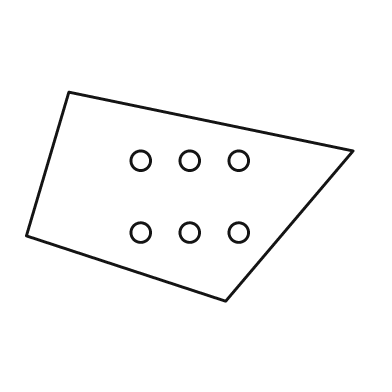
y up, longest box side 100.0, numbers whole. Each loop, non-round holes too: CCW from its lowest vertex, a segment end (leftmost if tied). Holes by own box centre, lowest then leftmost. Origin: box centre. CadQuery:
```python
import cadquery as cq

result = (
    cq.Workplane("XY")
    .moveTo(11.0, -32.0)
    .lineTo(50.0, 14.0)
    .lineTo(-37.0, 32.0)
    .lineTo(-50.0, -12.0)
    .close()
    .moveTo(-15.0, -11.0)
    .circle(3.0)
    .moveTo(0.0, -11.0)
    .circle(3.0)
    .moveTo(15.0, -11.0)
    .circle(3.0)
    .moveTo(-15.0, 11.0)
    .circle(3.0)
    .moveTo(0.0, 11.0)
    .circle(3.0)
    .moveTo(15.0, 11.0)
    .circle(3.0)
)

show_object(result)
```